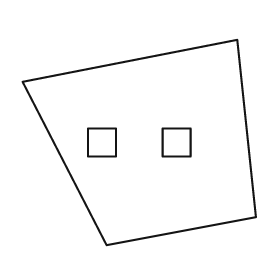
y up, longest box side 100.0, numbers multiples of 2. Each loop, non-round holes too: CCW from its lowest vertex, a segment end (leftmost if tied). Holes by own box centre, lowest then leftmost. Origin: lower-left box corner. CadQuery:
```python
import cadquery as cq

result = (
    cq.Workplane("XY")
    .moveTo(36.0, 0.0)
    .lineTo(100.0, 12.0)
    .lineTo(92.0, 88.0)
    .lineTo(0.0, 70.0)
    .close()
    .moveTo(28.0, 38.0)
    .lineTo(40.0, 38.0)
    .lineTo(40.0, 50.0)
    .lineTo(28.0, 50.0)
    .close()
    .moveTo(60.0, 38.0)
    .lineTo(72.0, 38.0)
    .lineTo(72.0, 50.0)
    .lineTo(60.0, 50.0)
    .close()
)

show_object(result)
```